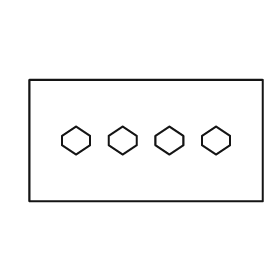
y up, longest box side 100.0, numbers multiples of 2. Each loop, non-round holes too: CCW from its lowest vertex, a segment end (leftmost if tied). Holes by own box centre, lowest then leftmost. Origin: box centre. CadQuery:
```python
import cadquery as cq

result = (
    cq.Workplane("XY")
    .moveTo(-50.0, -26.0)
    .lineTo(50.0, -26.0)
    .lineTo(50.0, 26.0)
    .lineTo(-50.0, 26.0)
    .close()
    .moveTo(-30.0, -6.0)
    .lineTo(-24.0, -2.0)
    .lineTo(-24.0, 2.0)
    .lineTo(-30.0, 6.0)
    .lineTo(-36.0, 2.0)
    .lineTo(-36.0, -2.0)
    .close()
    .moveTo(-10.0, -6.0)
    .lineTo(-4.0, -2.0)
    .lineTo(-4.0, 2.0)
    .lineTo(-10.0, 6.0)
    .lineTo(-16.0, 2.0)
    .lineTo(-16.0, -2.0)
    .close()
    .moveTo(10.0, -6.0)
    .lineTo(16.0, -2.0)
    .lineTo(16.0, 2.0)
    .lineTo(10.0, 6.0)
    .lineTo(4.0, 2.0)
    .lineTo(4.0, -2.0)
    .close()
    .moveTo(30.0, -6.0)
    .lineTo(36.0, -2.0)
    .lineTo(36.0, 2.0)
    .lineTo(30.0, 6.0)
    .lineTo(24.0, 2.0)
    .lineTo(24.0, -2.0)
    .close()
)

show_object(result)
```